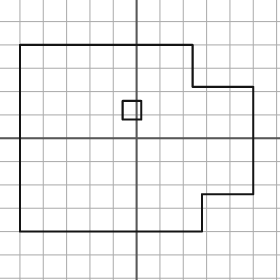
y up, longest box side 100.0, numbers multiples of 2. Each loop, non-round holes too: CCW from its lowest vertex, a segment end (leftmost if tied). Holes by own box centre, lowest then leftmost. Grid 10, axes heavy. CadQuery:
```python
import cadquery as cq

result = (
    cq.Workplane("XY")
    .moveTo(-50.0, -40.0)
    .lineTo(28.0, -40.0)
    .lineTo(28.0, -24.0)
    .lineTo(50.0, -24.0)
    .lineTo(50.0, 22.0)
    .lineTo(24.0, 22.0)
    .lineTo(24.0, 40.0)
    .lineTo(-50.0, 40.0)
    .close()
    .moveTo(-6.0, 8.0)
    .lineTo(2.0, 8.0)
    .lineTo(2.0, 16.0)
    .lineTo(-6.0, 16.0)
    .close()
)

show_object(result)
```